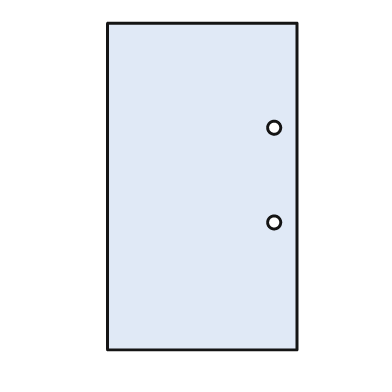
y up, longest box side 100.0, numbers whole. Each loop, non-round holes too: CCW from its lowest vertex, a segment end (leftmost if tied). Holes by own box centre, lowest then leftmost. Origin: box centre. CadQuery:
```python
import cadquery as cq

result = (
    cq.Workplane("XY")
    .moveTo(-29.0, -50.0)
    .lineTo(29.0, -50.0)
    .lineTo(29.0, 50.0)
    .lineTo(-29.0, 50.0)
    .close()
    .moveTo(22.0, -11.0)
    .circle(2.0)
    .moveTo(22.0, 18.0)
    .circle(2.0)
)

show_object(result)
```